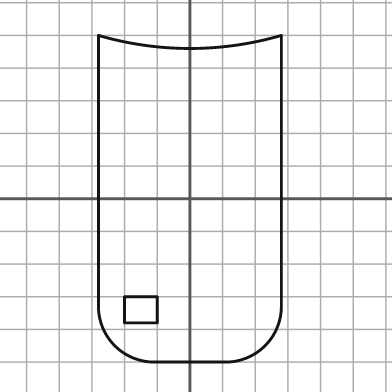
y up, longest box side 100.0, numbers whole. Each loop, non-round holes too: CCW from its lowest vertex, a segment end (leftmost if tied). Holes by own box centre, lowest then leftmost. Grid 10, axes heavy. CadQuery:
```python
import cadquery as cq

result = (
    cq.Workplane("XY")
    .moveTo(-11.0, -50.0)
    .lineTo(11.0, -50.0)
    .threePointArc((23.0, -45.0), (28.0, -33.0))
    .lineTo(28.0, 50.0)
    .threePointArc((0.0, 46.0), (-28.0, 50.0))
    .lineTo(-28.0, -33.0)
    .threePointArc((-23.0, -45.0), (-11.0, -50.0))
    .close()
    .moveTo(-20.0, -38.0)
    .lineTo(-10.0, -38.0)
    .lineTo(-10.0, -30.0)
    .lineTo(-20.0, -30.0)
    .close()
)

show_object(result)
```